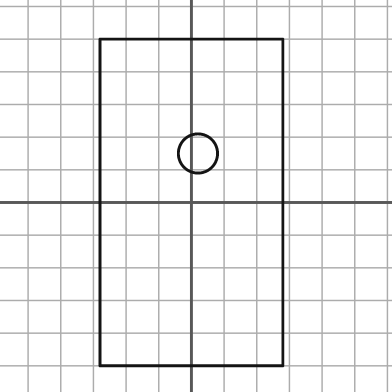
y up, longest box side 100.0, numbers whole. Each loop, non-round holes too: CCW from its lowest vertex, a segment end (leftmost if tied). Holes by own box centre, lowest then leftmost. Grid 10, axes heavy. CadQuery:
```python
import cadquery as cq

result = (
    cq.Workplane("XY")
    .moveTo(-28.0, -50.0)
    .lineTo(28.0, -50.0)
    .lineTo(28.0, 50.0)
    .lineTo(-28.0, 50.0)
    .close()
    .moveTo(2.0, 15.0)
    .circle(6.0)
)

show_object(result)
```